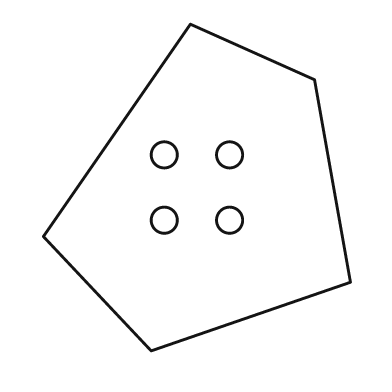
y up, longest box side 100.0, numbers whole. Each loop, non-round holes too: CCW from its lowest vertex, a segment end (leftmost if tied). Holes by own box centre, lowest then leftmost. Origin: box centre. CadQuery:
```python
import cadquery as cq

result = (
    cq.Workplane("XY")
    .moveTo(-14.0, -50.0)
    .lineTo(47.0, -29.0)
    .lineTo(36.0, 33.0)
    .lineTo(-2.0, 50.0)
    .lineTo(-47.0, -15.0)
    .close()
    .moveTo(-10.0, -10.0)
    .circle(4.0)
    .moveTo(10.0, -10.0)
    .circle(4.0)
    .moveTo(-10.0, 10.0)
    .circle(4.0)
    .moveTo(10.0, 10.0)
    .circle(4.0)
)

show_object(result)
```